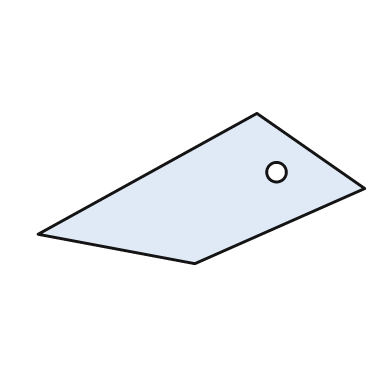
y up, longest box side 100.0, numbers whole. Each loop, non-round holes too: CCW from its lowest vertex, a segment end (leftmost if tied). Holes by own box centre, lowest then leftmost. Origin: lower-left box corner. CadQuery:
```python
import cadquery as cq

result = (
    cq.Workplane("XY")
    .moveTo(48.0, 0.0)
    .lineTo(100.0, 23.0)
    .lineTo(67.0, 46.0)
    .lineTo(0.0, 9.0)
    .close()
    .moveTo(73.0, 28.0)
    .circle(3.0)
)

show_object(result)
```